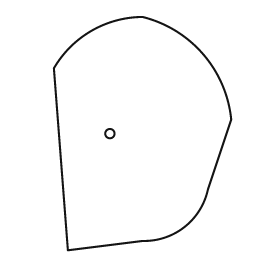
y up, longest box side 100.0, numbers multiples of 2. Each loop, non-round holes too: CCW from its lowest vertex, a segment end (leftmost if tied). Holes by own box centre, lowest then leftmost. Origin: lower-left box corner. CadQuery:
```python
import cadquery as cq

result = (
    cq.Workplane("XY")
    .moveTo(6.0, 0.0)
    .lineTo(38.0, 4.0)
    .threePointArc((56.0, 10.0), (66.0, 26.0))
    .lineTo(76.0, 56.0)
    .threePointArc((64.0, 84.0), (38.0, 100.0))
    .threePointArc((16.0, 94.0), (0.0, 78.0))
    .close()
    .moveTo(24.0, 50.0)
    .circle(2.0)
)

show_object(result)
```